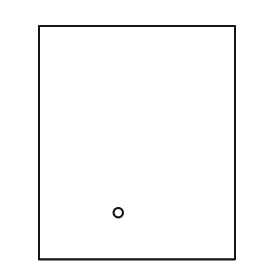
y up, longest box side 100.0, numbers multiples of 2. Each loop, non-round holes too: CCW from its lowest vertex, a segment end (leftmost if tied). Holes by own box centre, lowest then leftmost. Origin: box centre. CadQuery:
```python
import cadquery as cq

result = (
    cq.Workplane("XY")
    .moveTo(-42.0, -50.0)
    .lineTo(42.0, -50.0)
    .lineTo(42.0, 50.0)
    .lineTo(-42.0, 50.0)
    .close()
    .moveTo(-8.0, -30.0)
    .circle(2.0)
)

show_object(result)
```